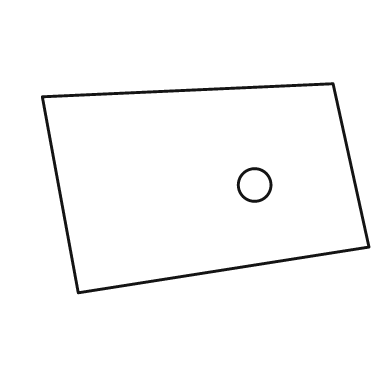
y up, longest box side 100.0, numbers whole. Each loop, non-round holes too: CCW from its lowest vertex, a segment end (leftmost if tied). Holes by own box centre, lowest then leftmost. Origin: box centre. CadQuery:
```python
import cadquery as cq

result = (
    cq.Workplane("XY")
    .moveTo(-39.0, -32.0)
    .lineTo(50.0, -18.0)
    .lineTo(39.0, 32.0)
    .lineTo(-50.0, 28.0)
    .close()
    .moveTo(15.0, 1.0)
    .circle(5.0)
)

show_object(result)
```